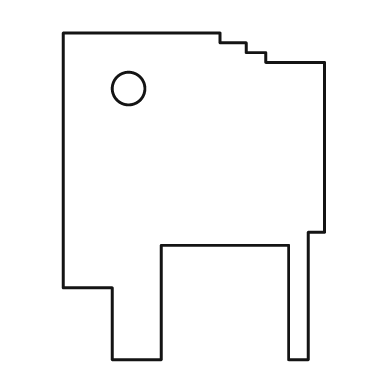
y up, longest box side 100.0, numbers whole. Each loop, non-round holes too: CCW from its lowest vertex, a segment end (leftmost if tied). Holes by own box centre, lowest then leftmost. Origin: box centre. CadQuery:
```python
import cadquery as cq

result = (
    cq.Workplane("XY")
    .moveTo(-25.0, -50.0)
    .lineTo(-10.0, -50.0)
    .lineTo(-10.0, -15.0)
    .lineTo(29.0, -15.0)
    .lineTo(29.0, -50.0)
    .lineTo(35.0, -50.0)
    .lineTo(35.0, -11.0)
    .lineTo(40.0, -11.0)
    .lineTo(40.0, 41.0)
    .lineTo(22.0, 41.0)
    .lineTo(22.0, 44.0)
    .lineTo(16.0, 44.0)
    .lineTo(16.0, 47.0)
    .lineTo(8.0, 47.0)
    .lineTo(8.0, 50.0)
    .lineTo(-40.0, 50.0)
    .lineTo(-40.0, -28.0)
    .lineTo(-25.0, -28.0)
    .close()
    .moveTo(-20.0, 33.0)
    .circle(5.0)
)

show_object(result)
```